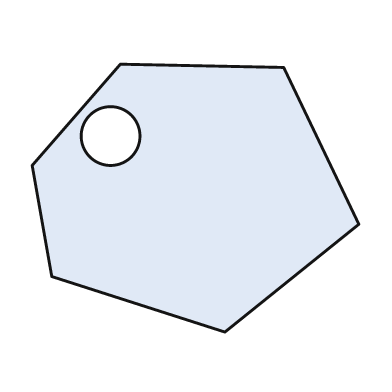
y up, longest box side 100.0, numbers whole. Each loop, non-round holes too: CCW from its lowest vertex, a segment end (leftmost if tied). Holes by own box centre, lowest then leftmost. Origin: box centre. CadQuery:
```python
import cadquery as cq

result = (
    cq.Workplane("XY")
    .moveTo(9.0, -41.0)
    .lineTo(50.0, -8.0)
    .lineTo(27.0, 40.0)
    .lineTo(-23.0, 41.0)
    .lineTo(-50.0, 10.0)
    .lineTo(-44.0, -24.0)
    .close()
    .moveTo(-26.0, 19.0)
    .circle(9.0)
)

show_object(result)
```